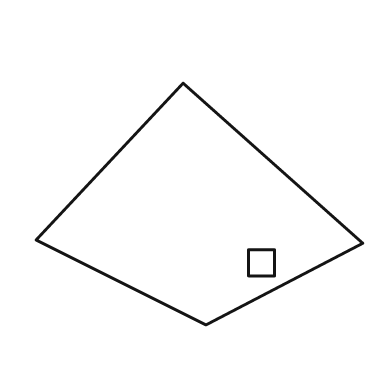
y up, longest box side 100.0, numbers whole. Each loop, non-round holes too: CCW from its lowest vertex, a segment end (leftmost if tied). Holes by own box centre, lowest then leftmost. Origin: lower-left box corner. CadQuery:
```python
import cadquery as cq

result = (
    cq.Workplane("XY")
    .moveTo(52.0, 0.0)
    .lineTo(100.0, 25.0)
    .lineTo(45.0, 74.0)
    .lineTo(0.0, 26.0)
    .close()
    .moveTo(65.0, 15.0)
    .lineTo(73.0, 15.0)
    .lineTo(73.0, 23.0)
    .lineTo(65.0, 23.0)
    .close()
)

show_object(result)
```